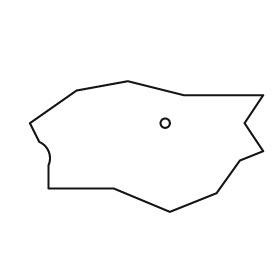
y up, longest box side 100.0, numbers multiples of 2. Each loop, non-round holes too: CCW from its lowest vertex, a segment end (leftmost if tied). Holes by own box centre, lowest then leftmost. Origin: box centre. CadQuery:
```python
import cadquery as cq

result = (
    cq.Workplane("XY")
    .moveTo(10.0, -28.0)
    .lineTo(30.0, -20.0)
    .lineTo(40.0, -6.0)
    .lineTo(50.0, -2.0)
    .lineTo(42.0, 10.0)
    .lineTo(50.0, 22.0)
    .lineTo(16.0, 22.0)
    .lineTo(-8.0, 28.0)
    .lineTo(-30.0, 24.0)
    .lineTo(-50.0, 10.0)
    .lineTo(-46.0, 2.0)
    .threePointArc((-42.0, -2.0), (-42.0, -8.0))
    .lineTo(-42.0, -18.0)
    .lineTo(-14.0, -18.0)
    .close()
    .moveTo(8.0, 10.0)
    .circle(2.0)
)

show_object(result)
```